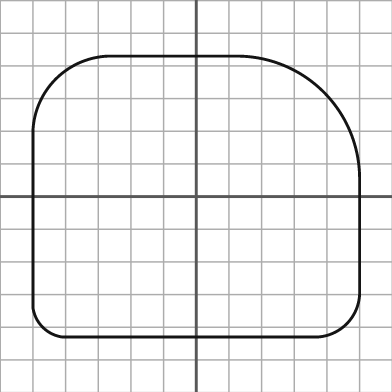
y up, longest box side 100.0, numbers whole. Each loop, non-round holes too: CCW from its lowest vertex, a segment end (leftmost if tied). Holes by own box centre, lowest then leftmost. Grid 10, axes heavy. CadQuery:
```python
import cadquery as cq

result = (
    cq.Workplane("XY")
    .moveTo(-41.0, -43.0)
    .lineTo(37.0, -43.0)
    .threePointArc((46.0, -39.0), (50.0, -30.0))
    .lineTo(50.0, 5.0)
    .threePointArc((39.0, 32.0), (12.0, 43.0))
    .lineTo(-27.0, 43.0)
    .threePointArc((-43.0, 36.0), (-50.0, 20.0))
    .lineTo(-50.0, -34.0)
    .threePointArc((-47.0, -40.0), (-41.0, -43.0))
    .close()
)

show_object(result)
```